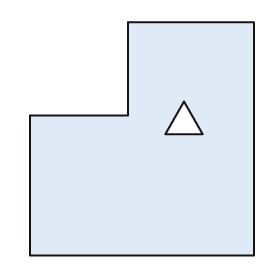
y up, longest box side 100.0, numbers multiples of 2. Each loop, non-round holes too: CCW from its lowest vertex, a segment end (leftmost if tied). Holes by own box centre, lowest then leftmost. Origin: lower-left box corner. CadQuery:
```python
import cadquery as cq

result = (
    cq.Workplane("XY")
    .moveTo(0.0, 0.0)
    .lineTo(96.0, 0.0)
    .lineTo(96.0, 100.0)
    .lineTo(42.0, 100.0)
    .lineTo(42.0, 60.0)
    .lineTo(0.0, 60.0)
    .close()
    .moveTo(58.0, 52.0)
    .lineTo(74.0, 52.0)
    .lineTo(66.0, 66.0)
    .close()
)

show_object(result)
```